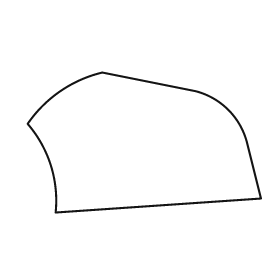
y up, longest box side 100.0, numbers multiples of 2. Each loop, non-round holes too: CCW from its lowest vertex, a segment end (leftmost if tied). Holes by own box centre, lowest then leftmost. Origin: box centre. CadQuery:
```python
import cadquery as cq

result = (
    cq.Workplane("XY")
    .moveTo(-38.0, -30.0)
    .lineTo(50.0, -24.0)
    .lineTo(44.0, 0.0)
    .threePointArc((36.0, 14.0), (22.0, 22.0))
    .lineTo(-18.0, 30.0)
    .threePointArc((-36.0, 22.0), (-50.0, 8.0))
    .threePointArc((-40.0, -10.0), (-38.0, -30.0))
    .close()
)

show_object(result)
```